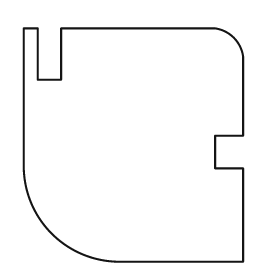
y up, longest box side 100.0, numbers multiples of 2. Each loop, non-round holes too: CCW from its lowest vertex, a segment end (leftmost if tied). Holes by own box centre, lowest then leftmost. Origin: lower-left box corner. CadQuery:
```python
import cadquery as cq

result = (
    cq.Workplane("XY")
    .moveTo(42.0, 0.0)
    .lineTo(94.0, 0.0)
    .lineTo(94.0, 40.0)
    .lineTo(82.0, 40.0)
    .lineTo(82.0, 54.0)
    .lineTo(94.0, 54.0)
    .lineTo(94.0, 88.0)
    .threePointArc((90.0, 96.0), (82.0, 100.0))
    .lineTo(16.0, 100.0)
    .lineTo(16.0, 78.0)
    .lineTo(6.0, 78.0)
    .lineTo(6.0, 100.0)
    .lineTo(0.0, 100.0)
    .lineTo(0.0, 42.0)
    .threePointArc((12.0, 12.0), (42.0, 0.0))
    .close()
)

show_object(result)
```